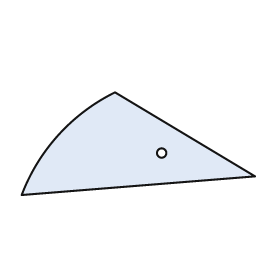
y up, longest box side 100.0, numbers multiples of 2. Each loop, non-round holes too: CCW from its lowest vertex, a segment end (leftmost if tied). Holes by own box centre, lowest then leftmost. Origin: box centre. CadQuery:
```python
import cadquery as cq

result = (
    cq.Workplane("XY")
    .moveTo(-50.0, -22.0)
    .lineTo(50.0, -14.0)
    .lineTo(-10.0, 22.0)
    .threePointArc((-34.0, 4.0), (-50.0, -22.0))
    .close()
    .moveTo(10.0, -4.0)
    .circle(2.0)
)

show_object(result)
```